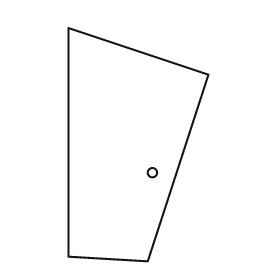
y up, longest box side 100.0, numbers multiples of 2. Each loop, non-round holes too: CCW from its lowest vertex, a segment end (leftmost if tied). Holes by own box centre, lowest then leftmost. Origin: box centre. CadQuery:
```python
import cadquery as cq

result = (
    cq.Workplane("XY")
    .moveTo(4.0, -50.0)
    .lineTo(30.0, 30.0)
    .lineTo(-30.0, 50.0)
    .lineTo(-30.0, -48.0)
    .close()
    .moveTo(6.0, -12.0)
    .circle(2.0)
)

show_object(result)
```